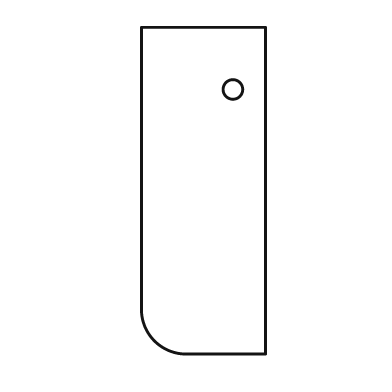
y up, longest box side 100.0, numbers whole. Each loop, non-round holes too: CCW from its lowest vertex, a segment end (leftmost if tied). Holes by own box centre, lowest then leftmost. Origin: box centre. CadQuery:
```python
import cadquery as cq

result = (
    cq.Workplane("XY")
    .moveTo(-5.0, -50.0)
    .lineTo(19.0, -50.0)
    .lineTo(19.0, 50.0)
    .lineTo(-19.0, 50.0)
    .lineTo(-19.0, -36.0)
    .threePointArc((-15.0, -46.0), (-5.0, -50.0))
    .close()
    .moveTo(9.0, 31.0)
    .circle(3.0)
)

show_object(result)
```